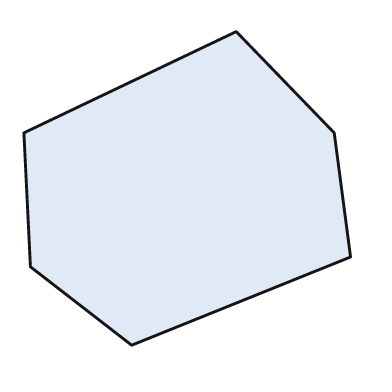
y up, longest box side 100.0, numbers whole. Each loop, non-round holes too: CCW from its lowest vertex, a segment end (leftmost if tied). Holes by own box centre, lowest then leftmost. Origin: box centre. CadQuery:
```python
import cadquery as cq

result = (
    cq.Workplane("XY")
    .moveTo(-17.0, -48.0)
    .lineTo(50.0, -21.0)
    .lineTo(45.0, 17.0)
    .lineTo(15.0, 48.0)
    .lineTo(-50.0, 17.0)
    .lineTo(-48.0, -24.0)
    .close()
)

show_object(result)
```